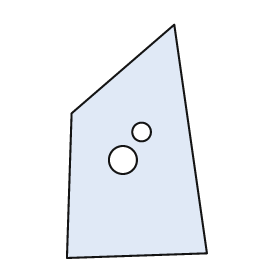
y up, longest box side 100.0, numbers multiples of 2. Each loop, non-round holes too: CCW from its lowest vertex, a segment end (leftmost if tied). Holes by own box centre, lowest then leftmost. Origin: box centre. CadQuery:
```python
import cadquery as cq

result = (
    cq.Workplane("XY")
    .moveTo(-30.0, -50.0)
    .lineTo(30.0, -48.0)
    .lineTo(16.0, 50.0)
    .lineTo(-28.0, 12.0)
    .close()
    .moveTo(-6.0, -8.0)
    .circle(6.0)
    .moveTo(2.0, 4.0)
    .circle(4.0)
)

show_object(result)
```